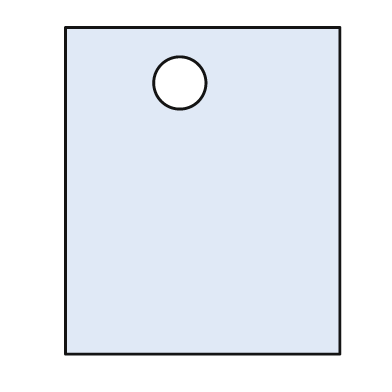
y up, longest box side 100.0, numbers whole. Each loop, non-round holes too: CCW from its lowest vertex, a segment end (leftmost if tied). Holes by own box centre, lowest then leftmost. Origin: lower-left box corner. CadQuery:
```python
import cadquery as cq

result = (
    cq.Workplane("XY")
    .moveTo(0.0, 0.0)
    .lineTo(84.0, 0.0)
    .lineTo(84.0, 100.0)
    .lineTo(0.0, 100.0)
    .close()
    .moveTo(35.0, 83.0)
    .circle(8.0)
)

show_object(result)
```